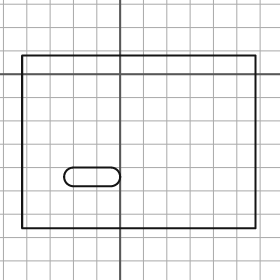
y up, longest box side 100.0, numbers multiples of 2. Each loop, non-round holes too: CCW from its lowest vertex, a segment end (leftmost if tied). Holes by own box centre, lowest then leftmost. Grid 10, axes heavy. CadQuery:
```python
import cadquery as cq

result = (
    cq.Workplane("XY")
    .moveTo(-42.0, -66.0)
    .lineTo(58.0, -66.0)
    .lineTo(58.0, 8.0)
    .lineTo(-42.0, 8.0)
    .close()
    .moveTo(-20.0, -48.0)
    .lineTo(-4.0, -48.0)
    .threePointArc((0.0, -44.0), (-4.0, -40.0))
    .lineTo(-20.0, -40.0)
    .threePointArc((-24.0, -44.0), (-20.0, -48.0))
    .close()
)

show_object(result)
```